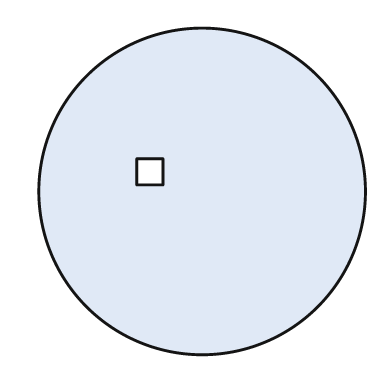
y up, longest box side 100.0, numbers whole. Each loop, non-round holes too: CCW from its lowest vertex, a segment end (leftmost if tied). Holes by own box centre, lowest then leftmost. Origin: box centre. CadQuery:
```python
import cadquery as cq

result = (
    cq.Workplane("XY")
    .moveTo(0.0, 0.0)
    .circle(50.0)
    .moveTo(-20.0, 2.0)
    .lineTo(-12.0, 2.0)
    .lineTo(-12.0, 10.0)
    .lineTo(-20.0, 10.0)
    .close()
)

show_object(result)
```